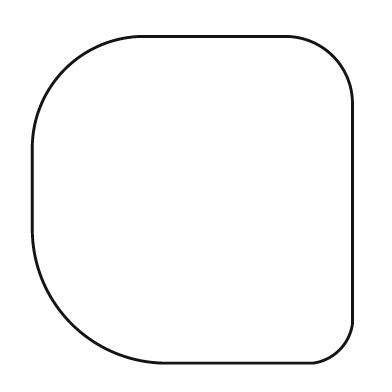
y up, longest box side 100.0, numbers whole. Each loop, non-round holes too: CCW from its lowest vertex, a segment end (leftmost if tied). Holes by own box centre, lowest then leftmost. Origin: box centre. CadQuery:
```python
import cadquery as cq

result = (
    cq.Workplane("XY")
    .moveTo(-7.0, -50.0)
    .lineTo(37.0, -50.0)
    .threePointArc((45.0, -46.0), (49.0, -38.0))
    .lineTo(49.0, 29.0)
    .threePointArc((43.0, 44.0), (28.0, 50.0))
    .lineTo(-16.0, 50.0)
    .threePointArc((-39.0, 40.0), (-49.0, 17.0))
    .lineTo(-49.0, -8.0)
    .threePointArc((-37.0, -38.0), (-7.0, -50.0))
    .close()
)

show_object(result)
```